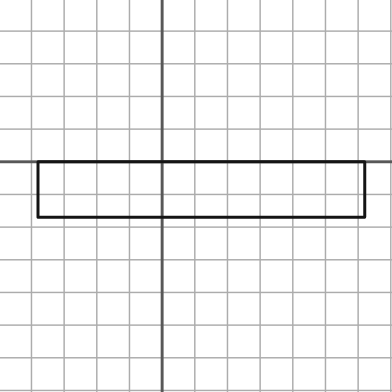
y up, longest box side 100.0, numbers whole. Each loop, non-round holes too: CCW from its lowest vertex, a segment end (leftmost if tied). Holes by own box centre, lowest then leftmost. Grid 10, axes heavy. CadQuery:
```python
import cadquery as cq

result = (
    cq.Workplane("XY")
    .moveTo(-38.0, -17.0)
    .lineTo(62.0, -17.0)
    .lineTo(62.0, 0.0)
    .lineTo(-38.0, 0.0)
    .close()
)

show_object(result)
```